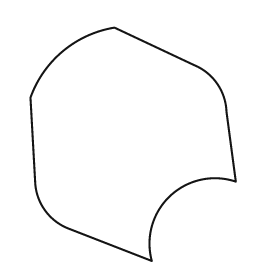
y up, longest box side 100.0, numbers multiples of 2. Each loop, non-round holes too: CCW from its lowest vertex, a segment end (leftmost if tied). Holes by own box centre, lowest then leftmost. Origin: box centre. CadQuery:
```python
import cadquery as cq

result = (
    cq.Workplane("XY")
    .moveTo(8.0, -50.0)
    .threePointArc((16.0, -22.0), (44.0, -16.0))
    .lineTo(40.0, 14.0)
    .threePointArc((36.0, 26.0), (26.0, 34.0))
    .lineTo(-8.0, 50.0)
    .threePointArc((-30.0, 40.0), (-44.0, 20.0))
    .lineTo(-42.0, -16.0)
    .threePointArc((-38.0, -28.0), (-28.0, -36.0))
    .close()
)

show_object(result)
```